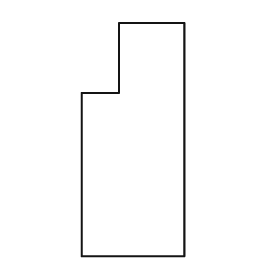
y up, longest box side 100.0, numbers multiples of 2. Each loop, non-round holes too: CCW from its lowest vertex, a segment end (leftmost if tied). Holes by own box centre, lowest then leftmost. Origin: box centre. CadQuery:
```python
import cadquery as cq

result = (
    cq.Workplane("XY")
    .moveTo(-22.0, -50.0)
    .lineTo(22.0, -50.0)
    .lineTo(22.0, 50.0)
    .lineTo(-6.0, 50.0)
    .lineTo(-6.0, 20.0)
    .lineTo(-22.0, 20.0)
    .close()
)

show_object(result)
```